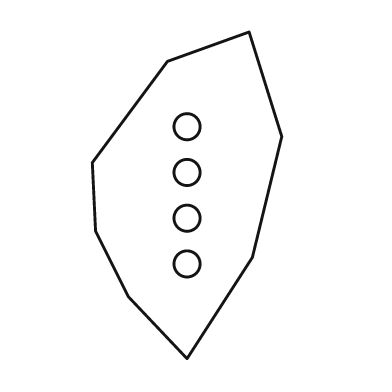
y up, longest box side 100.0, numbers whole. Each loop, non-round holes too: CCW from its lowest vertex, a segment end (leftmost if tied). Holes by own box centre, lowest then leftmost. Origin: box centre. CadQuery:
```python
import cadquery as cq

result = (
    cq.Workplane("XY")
    .moveTo(0.0, -50.0)
    .lineTo(20.0, -19.0)
    .lineTo(29.0, 18.0)
    .lineTo(19.0, 50.0)
    .lineTo(-6.0, 41.0)
    .lineTo(-29.0, 10.0)
    .lineTo(-28.0, -11.0)
    .lineTo(-18.0, -31.0)
    .close()
    .moveTo(0.0, -21.0)
    .circle(4.0)
    .moveTo(0.0, -7.0)
    .circle(4.0)
    .moveTo(0.0, 7.0)
    .circle(4.0)
    .moveTo(0.0, 21.0)
    .circle(4.0)
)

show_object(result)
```